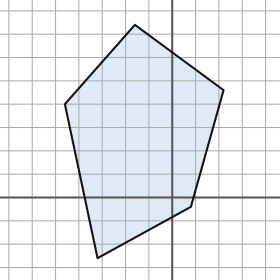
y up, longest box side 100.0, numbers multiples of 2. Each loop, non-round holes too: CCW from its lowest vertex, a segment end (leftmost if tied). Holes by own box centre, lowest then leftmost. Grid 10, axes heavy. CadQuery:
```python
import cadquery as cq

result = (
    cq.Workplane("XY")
    .moveTo(-32.0, -26.0)
    .lineTo(8.0, -4.0)
    .lineTo(22.0, 46.0)
    .lineTo(-16.0, 74.0)
    .lineTo(-46.0, 40.0)
    .close()
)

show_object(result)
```